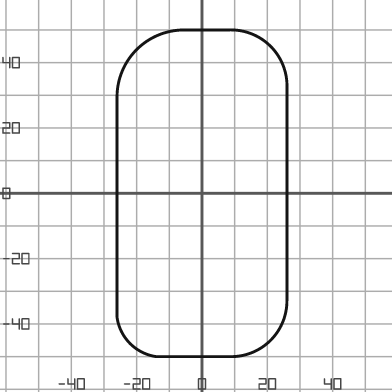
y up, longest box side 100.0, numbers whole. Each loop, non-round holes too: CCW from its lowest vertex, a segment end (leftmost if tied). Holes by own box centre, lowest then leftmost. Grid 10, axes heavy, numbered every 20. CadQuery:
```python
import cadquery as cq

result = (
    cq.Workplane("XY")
    .moveTo(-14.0, -50.0)
    .lineTo(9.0, -50.0)
    .threePointArc((21.0, -45.0), (26.0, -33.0))
    .lineTo(26.0, 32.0)
    .threePointArc((21.0, 45.0), (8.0, 50.0))
    .lineTo(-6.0, 50.0)
    .threePointArc((-20.0, 44.0), (-26.0, 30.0))
    .lineTo(-26.0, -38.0)
    .threePointArc((-22.0, -46.0), (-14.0, -50.0))
    .close()
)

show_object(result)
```